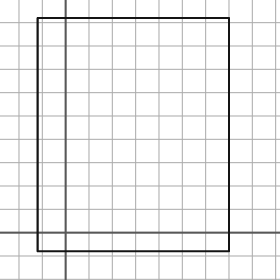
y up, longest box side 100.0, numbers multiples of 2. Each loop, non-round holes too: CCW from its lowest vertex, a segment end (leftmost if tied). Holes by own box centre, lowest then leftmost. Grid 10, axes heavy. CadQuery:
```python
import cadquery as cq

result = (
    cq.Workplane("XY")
    .moveTo(-12.0, -8.0)
    .lineTo(70.0, -8.0)
    .lineTo(70.0, 92.0)
    .lineTo(-12.0, 92.0)
    .close()
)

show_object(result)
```